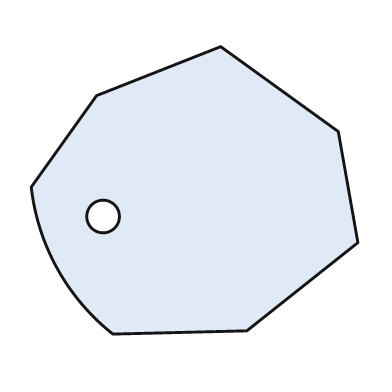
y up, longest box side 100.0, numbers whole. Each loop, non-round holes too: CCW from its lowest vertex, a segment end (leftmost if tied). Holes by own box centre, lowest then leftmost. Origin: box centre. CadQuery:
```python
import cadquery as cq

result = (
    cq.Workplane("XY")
    .moveTo(-25.0, -44.0)
    .lineTo(16.0, -43.0)
    .lineTo(50.0, -16.0)
    .lineTo(44.0, 18.0)
    .lineTo(8.0, 44.0)
    .lineTo(-30.0, 29.0)
    .lineTo(-50.0, 1.0)
    .threePointArc((-42.0, -24.0), (-25.0, -44.0))
    .close()
    .moveTo(-28.0, -8.0)
    .circle(5.0)
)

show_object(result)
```